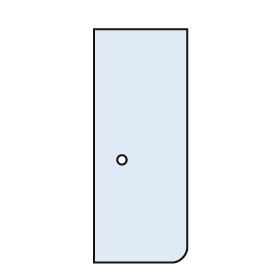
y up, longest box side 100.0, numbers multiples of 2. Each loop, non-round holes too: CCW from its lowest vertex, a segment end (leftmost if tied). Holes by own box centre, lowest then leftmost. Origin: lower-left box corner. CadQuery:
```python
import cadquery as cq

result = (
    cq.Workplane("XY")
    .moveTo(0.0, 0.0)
    .lineTo(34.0, 0.0)
    .threePointArc((38.0, 2.0), (40.0, 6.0))
    .lineTo(40.0, 100.0)
    .lineTo(0.0, 100.0)
    .close()
    .moveTo(12.0, 44.0)
    .circle(2.0)
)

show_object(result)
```